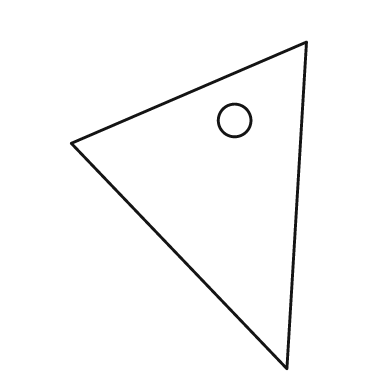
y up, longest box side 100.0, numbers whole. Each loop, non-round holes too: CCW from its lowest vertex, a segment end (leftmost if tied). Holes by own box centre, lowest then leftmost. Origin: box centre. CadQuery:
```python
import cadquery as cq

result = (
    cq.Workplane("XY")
    .moveTo(30.0, -50.0)
    .lineTo(36.0, 50.0)
    .lineTo(-36.0, 19.0)
    .close()
    .moveTo(14.0, 26.0)
    .circle(5.0)
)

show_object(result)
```